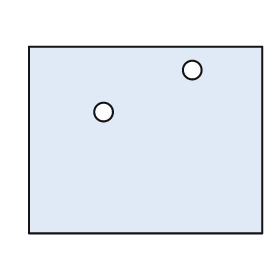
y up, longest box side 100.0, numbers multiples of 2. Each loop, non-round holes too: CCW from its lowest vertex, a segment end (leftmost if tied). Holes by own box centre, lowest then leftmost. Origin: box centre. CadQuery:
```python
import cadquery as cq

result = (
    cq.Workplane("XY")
    .moveTo(-50.0, -40.0)
    .lineTo(50.0, -40.0)
    .lineTo(50.0, 40.0)
    .lineTo(-50.0, 40.0)
    .close()
    .moveTo(-18.0, 12.0)
    .circle(4.0)
    .moveTo(20.0, 30.0)
    .circle(4.0)
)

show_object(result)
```